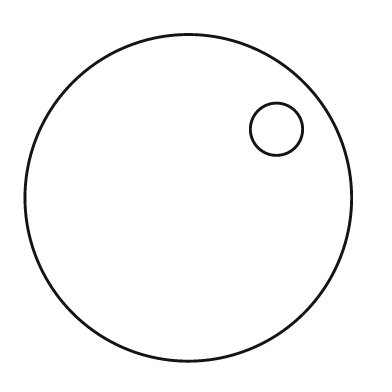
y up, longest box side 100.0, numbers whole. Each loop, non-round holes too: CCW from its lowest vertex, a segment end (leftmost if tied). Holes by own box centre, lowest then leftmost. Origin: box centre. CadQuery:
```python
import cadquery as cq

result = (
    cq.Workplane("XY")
    .moveTo(0.0, 0.0)
    .circle(50.0)
    .moveTo(27.0, 21.0)
    .circle(8.0)
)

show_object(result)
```